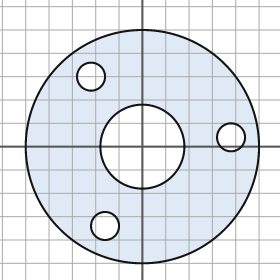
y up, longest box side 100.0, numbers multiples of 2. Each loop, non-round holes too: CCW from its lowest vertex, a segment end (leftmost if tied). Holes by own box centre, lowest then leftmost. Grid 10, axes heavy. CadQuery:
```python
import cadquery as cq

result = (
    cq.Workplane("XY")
    .moveTo(0.0, 0.0)
    .circle(50.0)
    .moveTo(-16.0, -34.0)
    .circle(6.0)
    .moveTo(0.0, 0.0)
    .circle(18.0)
    .moveTo(38.0, 4.0)
    .circle(6.0)
    .moveTo(-22.0, 30.0)
    .circle(6.0)
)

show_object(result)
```